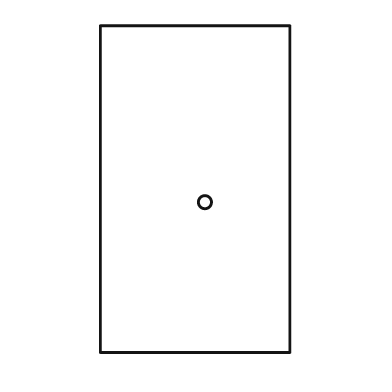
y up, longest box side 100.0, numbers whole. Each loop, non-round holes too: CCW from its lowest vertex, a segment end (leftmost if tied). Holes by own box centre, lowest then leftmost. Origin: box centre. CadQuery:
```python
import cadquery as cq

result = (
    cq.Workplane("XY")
    .moveTo(-29.0, -50.0)
    .lineTo(29.0, -50.0)
    .lineTo(29.0, 50.0)
    .lineTo(-29.0, 50.0)
    .close()
    .moveTo(3.0, -4.0)
    .circle(2.0)
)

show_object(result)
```